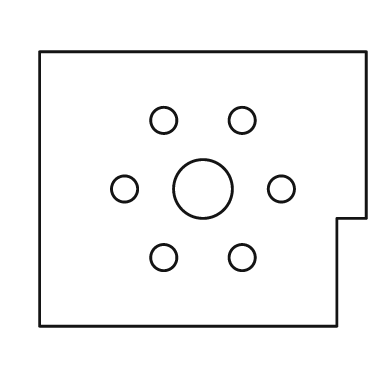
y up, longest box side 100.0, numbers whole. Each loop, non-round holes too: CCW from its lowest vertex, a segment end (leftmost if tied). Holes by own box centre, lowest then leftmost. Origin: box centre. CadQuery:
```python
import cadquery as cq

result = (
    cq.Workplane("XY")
    .moveTo(-50.0, -42.0)
    .lineTo(41.0, -42.0)
    .lineTo(41.0, -9.0)
    .lineTo(50.0, -9.0)
    .lineTo(50.0, 42.0)
    .lineTo(-50.0, 42.0)
    .close()
    .moveTo(-12.0, -21.0)
    .circle(4.0)
    .moveTo(12.0, -21.0)
    .circle(4.0)
    .moveTo(-24.0, 0.0)
    .circle(4.0)
    .moveTo(0.0, 0.0)
    .circle(9.0)
    .moveTo(24.0, 0.0)
    .circle(4.0)
    .moveTo(-12.0, 21.0)
    .circle(4.0)
    .moveTo(12.0, 21.0)
    .circle(4.0)
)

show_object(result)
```